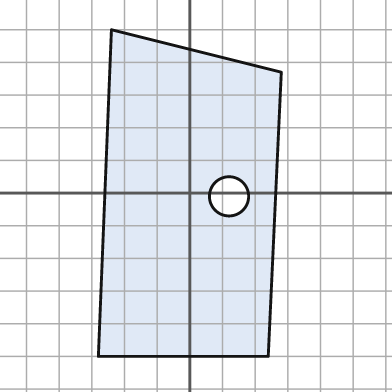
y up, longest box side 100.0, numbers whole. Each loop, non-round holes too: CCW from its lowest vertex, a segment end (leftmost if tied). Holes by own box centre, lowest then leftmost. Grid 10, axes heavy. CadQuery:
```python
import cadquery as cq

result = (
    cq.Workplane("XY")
    .moveTo(-28.0, -50.0)
    .lineTo(24.0, -50.0)
    .lineTo(28.0, 37.0)
    .lineTo(-24.0, 50.0)
    .close()
    .moveTo(12.0, -1.0)
    .circle(6.0)
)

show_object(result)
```